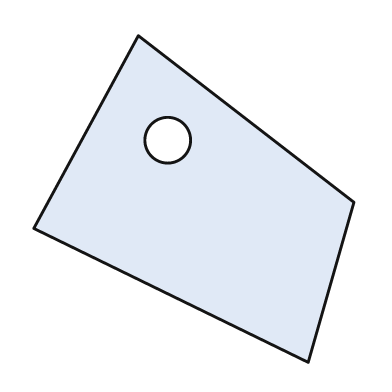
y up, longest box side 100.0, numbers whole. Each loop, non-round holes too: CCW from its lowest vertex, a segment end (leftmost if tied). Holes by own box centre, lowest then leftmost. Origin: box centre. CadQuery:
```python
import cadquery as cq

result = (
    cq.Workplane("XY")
    .moveTo(35.0, -50.0)
    .lineTo(49.0, -1.0)
    .lineTo(-17.0, 50.0)
    .lineTo(-49.0, -9.0)
    .close()
    .moveTo(-8.0, 18.0)
    .circle(7.0)
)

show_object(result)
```